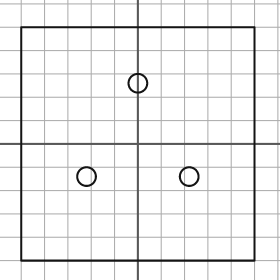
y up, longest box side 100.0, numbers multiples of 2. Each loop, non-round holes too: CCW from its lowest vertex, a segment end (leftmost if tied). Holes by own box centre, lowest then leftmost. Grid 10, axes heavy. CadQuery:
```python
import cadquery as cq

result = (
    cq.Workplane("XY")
    .moveTo(-50.0, -50.0)
    .lineTo(50.0, -50.0)
    .lineTo(50.0, 50.0)
    .lineTo(-50.0, 50.0)
    .close()
    .moveTo(-22.0, -14.0)
    .circle(4.0)
    .moveTo(22.0, -14.0)
    .circle(4.0)
    .moveTo(0.0, 26.0)
    .circle(4.0)
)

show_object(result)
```